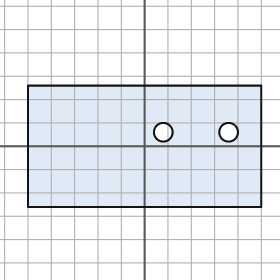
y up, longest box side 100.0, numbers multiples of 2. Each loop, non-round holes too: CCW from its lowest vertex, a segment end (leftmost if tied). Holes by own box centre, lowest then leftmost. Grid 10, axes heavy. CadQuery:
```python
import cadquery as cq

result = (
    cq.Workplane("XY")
    .moveTo(-50.0, -26.0)
    .lineTo(50.0, -26.0)
    .lineTo(50.0, 26.0)
    .lineTo(-50.0, 26.0)
    .close()
    .moveTo(8.0, 6.0)
    .circle(4.0)
    .moveTo(36.0, 6.0)
    .circle(4.0)
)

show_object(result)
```